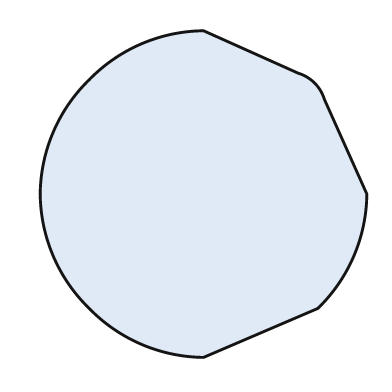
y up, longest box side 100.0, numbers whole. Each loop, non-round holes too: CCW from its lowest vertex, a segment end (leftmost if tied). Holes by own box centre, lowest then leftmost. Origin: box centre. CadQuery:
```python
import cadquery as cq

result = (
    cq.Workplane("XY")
    .moveTo(0.0, -50.0)
    .lineTo(35.0, -35.0)
    .threePointArc((46.0, -19.0), (50.0, 0.0))
    .lineTo(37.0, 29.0)
    .threePointArc((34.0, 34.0), (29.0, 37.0))
    .lineTo(0.0, 50.0)
    .threePointArc((-19.0, 46.0), (-35.0, 35.0))
    .threePointArc((-46.0, 19.0), (-50.0, 0.0))
    .threePointArc((-46.0, -19.0), (-35.0, -35.0))
    .threePointArc((-19.0, -46.0), (0.0, -50.0))
    .close()
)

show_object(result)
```